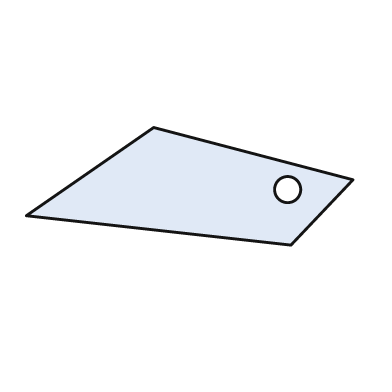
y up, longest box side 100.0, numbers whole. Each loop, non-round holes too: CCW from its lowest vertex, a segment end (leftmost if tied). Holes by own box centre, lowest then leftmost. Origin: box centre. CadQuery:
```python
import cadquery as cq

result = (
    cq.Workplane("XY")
    .moveTo(31.0, -18.0)
    .lineTo(50.0, 2.0)
    .lineTo(-11.0, 18.0)
    .lineTo(-50.0, -9.0)
    .close()
    .moveTo(30.0, -1.0)
    .circle(4.0)
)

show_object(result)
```